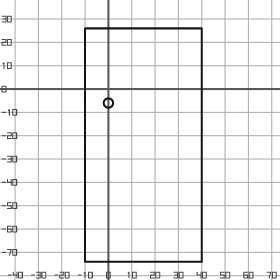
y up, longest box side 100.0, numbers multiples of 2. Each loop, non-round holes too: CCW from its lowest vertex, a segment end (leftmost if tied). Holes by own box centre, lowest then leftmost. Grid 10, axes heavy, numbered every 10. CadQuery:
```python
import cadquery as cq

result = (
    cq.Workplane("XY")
    .moveTo(-10.0, -74.0)
    .lineTo(40.0, -74.0)
    .lineTo(40.0, 26.0)
    .lineTo(-10.0, 26.0)
    .close()
    .moveTo(0.0, -6.0)
    .circle(2.0)
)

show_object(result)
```